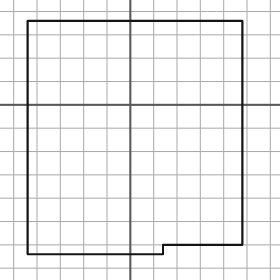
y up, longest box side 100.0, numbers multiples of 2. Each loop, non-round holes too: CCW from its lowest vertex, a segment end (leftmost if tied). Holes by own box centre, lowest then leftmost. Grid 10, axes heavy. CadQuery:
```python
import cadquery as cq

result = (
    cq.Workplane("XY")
    .moveTo(-44.0, -64.0)
    .lineTo(14.0, -64.0)
    .lineTo(14.0, -60.0)
    .lineTo(48.0, -60.0)
    .lineTo(48.0, 36.0)
    .lineTo(-44.0, 36.0)
    .close()
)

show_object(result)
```